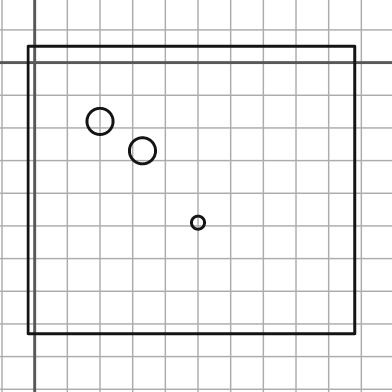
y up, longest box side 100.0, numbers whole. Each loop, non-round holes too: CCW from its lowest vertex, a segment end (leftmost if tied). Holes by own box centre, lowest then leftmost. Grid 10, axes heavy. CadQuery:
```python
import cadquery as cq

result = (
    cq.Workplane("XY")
    .moveTo(-2.0, -83.0)
    .lineTo(98.0, -83.0)
    .lineTo(98.0, 5.0)
    .lineTo(-2.0, 5.0)
    .close()
    .moveTo(50.0, -49.0)
    .circle(2.0)
    .moveTo(33.0, -27.0)
    .circle(4.0)
    .moveTo(20.0, -18.0)
    .circle(4.0)
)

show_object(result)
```